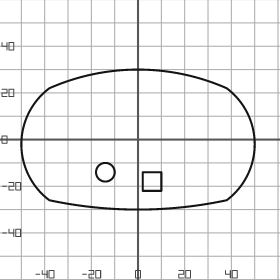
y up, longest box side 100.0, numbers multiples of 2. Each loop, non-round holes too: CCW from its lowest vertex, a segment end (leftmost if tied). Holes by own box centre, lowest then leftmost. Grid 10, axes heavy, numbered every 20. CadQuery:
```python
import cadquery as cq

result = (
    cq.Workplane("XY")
    .moveTo(-38.0, -26.0)
    .threePointArc((0.0, -30.0), (38.0, -26.0))
    .threePointArc((50.0, -2.0), (38.0, 22.0))
    .threePointArc((0.0, 30.0), (-38.0, 22.0))
    .threePointArc((-50.0, -2.0), (-38.0, -26.0))
    .close()
    .moveTo(2.0, -22.0)
    .lineTo(10.0, -22.0)
    .lineTo(10.0, -14.0)
    .lineTo(2.0, -14.0)
    .close()
    .moveTo(-14.0, -14.0)
    .circle(4.0)
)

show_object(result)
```